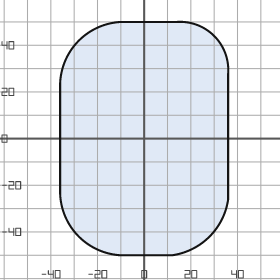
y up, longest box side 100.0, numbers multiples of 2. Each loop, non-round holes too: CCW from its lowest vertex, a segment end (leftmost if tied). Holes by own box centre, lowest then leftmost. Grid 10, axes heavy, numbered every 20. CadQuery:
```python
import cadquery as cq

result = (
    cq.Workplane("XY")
    .moveTo(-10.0, -50.0)
    .lineTo(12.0, -50.0)
    .threePointArc((28.0, -42.0), (36.0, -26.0))
    .lineTo(36.0, 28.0)
    .threePointArc((30.0, 44.0), (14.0, 50.0))
    .lineTo(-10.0, 50.0)
    .threePointArc((-28.0, 42.0), (-36.0, 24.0))
    .lineTo(-36.0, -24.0)
    .threePointArc((-28.0, -42.0), (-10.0, -50.0))
    .close()
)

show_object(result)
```